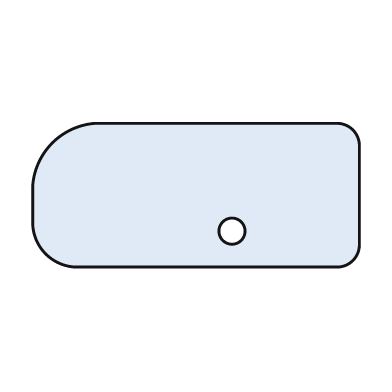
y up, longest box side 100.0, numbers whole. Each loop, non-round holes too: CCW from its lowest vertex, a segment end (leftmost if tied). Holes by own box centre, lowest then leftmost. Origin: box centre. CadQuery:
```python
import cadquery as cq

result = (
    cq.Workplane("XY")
    .moveTo(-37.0, -22.0)
    .lineTo(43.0, -22.0)
    .threePointArc((48.0, -20.0), (50.0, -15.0))
    .lineTo(50.0, 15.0)
    .threePointArc((48.0, 20.0), (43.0, 22.0))
    .lineTo(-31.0, 22.0)
    .threePointArc((-44.0, 16.0), (-50.0, 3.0))
    .lineTo(-50.0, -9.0)
    .threePointArc((-46.0, -18.0), (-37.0, -22.0))
    .close()
    .moveTo(11.0, -11.0)
    .circle(4.0)
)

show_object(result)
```